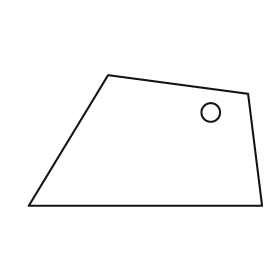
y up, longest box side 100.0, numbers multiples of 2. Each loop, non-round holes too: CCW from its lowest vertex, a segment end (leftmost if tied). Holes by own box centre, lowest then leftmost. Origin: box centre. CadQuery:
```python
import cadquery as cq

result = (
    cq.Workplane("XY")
    .moveTo(-50.0, -28.0)
    .lineTo(50.0, -28.0)
    .lineTo(44.0, 20.0)
    .lineTo(-16.0, 28.0)
    .close()
    .moveTo(28.0, 12.0)
    .circle(4.0)
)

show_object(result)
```